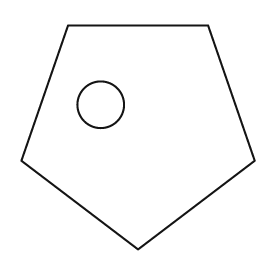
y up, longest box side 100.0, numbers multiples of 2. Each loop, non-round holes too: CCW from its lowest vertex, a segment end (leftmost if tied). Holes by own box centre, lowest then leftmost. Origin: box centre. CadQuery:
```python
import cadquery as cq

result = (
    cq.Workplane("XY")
    .moveTo(0.0, -48.0)
    .lineTo(50.0, -10.0)
    .lineTo(30.0, 48.0)
    .lineTo(-30.0, 48.0)
    .lineTo(-50.0, -10.0)
    .close()
    .moveTo(-16.0, 14.0)
    .circle(10.0)
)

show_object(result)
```